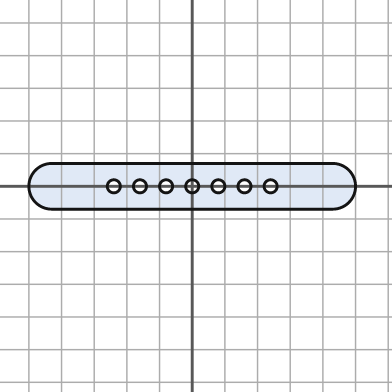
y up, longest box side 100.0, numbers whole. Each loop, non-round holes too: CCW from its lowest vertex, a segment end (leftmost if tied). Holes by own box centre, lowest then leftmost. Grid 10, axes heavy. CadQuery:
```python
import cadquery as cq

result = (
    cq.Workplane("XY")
    .moveTo(-43.0, -7.0)
    .lineTo(43.0, -7.0)
    .threePointArc((50.0, 0.0), (43.0, 7.0))
    .lineTo(-43.0, 7.0)
    .threePointArc((-50.0, 0.0), (-43.0, -7.0))
    .close()
    .moveTo(-24.0, 0.0)
    .circle(2.0)
    .moveTo(-16.0, 0.0)
    .circle(2.0)
    .moveTo(-8.0, 0.0)
    .circle(2.0)
    .moveTo(0.0, 0.0)
    .circle(2.0)
    .moveTo(8.0, 0.0)
    .circle(2.0)
    .moveTo(16.0, 0.0)
    .circle(2.0)
    .moveTo(24.0, 0.0)
    .circle(2.0)
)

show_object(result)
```